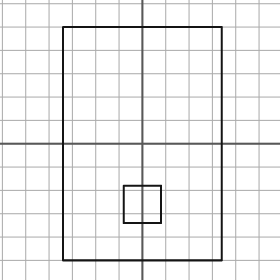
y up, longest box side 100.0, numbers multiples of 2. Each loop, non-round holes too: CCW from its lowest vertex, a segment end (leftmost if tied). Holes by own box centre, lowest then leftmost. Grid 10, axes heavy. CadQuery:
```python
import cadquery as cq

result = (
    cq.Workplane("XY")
    .moveTo(-34.0, -50.0)
    .lineTo(34.0, -50.0)
    .lineTo(34.0, 50.0)
    .lineTo(-34.0, 50.0)
    .close()
    .moveTo(-8.0, -34.0)
    .lineTo(8.0, -34.0)
    .lineTo(8.0, -18.0)
    .lineTo(-8.0, -18.0)
    .close()
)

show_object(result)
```